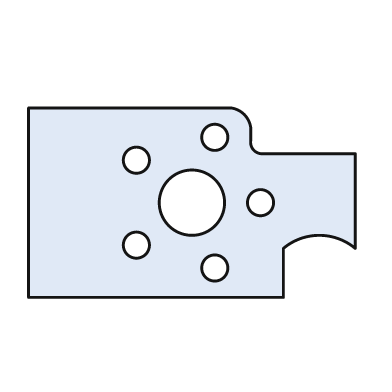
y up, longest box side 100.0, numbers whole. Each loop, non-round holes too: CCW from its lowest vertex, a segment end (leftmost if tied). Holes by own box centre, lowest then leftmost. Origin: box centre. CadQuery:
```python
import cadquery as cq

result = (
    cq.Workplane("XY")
    .moveTo(-50.0, -29.0)
    .lineTo(28.0, -29.0)
    .lineTo(28.0, -14.0)
    .threePointArc((39.0, -10.0), (50.0, -14.0))
    .lineTo(50.0, 15.0)
    .lineTo(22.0, 15.0)
    .threePointArc((19.0, 16.0), (18.0, 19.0))
    .lineTo(18.0, 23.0)
    .threePointArc((16.0, 27.0), (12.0, 29.0))
    .lineTo(-50.0, 29.0)
    .close()
    .moveTo(7.0, -20.0)
    .circle(4.0)
    .moveTo(-17.0, -13.0)
    .circle(4.0)
    .moveTo(0.0, 0.0)
    .circle(10.0)
    .moveTo(21.0, 0.0)
    .circle(4.0)
    .moveTo(-17.0, 13.0)
    .circle(4.0)
    .moveTo(7.0, 20.0)
    .circle(4.0)
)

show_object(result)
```